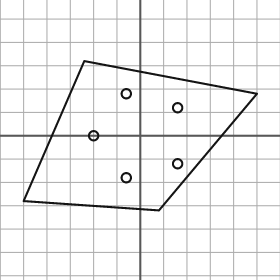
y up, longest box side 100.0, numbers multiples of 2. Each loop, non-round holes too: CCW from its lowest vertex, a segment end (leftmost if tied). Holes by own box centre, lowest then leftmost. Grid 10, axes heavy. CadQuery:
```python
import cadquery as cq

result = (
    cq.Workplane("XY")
    .moveTo(8.0, -32.0)
    .lineTo(50.0, 18.0)
    .lineTo(-24.0, 32.0)
    .lineTo(-50.0, -28.0)
    .close()
    .moveTo(-6.0, -18.0)
    .circle(2.0)
    .moveTo(16.0, -12.0)
    .circle(2.0)
    .moveTo(-20.0, 0.0)
    .circle(2.0)
    .moveTo(16.0, 12.0)
    .circle(2.0)
    .moveTo(-6.0, 18.0)
    .circle(2.0)
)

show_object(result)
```